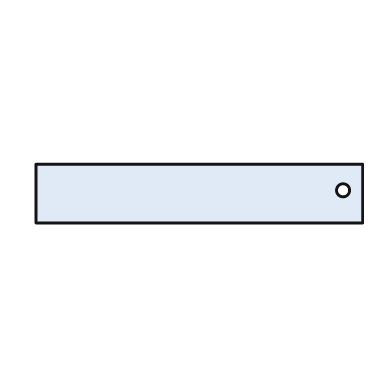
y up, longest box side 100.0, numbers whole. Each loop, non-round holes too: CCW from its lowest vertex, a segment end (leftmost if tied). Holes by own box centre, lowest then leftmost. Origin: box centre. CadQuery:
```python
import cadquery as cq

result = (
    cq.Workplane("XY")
    .moveTo(-50.0, -9.0)
    .lineTo(50.0, -9.0)
    .lineTo(50.0, 9.0)
    .lineTo(-50.0, 9.0)
    .close()
    .moveTo(44.0, 1.0)
    .circle(2.0)
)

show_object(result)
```